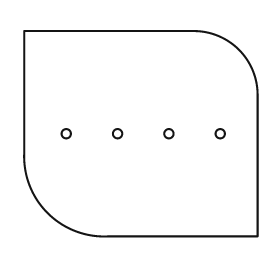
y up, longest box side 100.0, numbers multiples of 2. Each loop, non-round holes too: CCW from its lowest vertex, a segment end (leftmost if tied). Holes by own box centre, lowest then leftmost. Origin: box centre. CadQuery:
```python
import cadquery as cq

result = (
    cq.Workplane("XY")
    .moveTo(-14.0, -44.0)
    .lineTo(50.0, -44.0)
    .lineTo(50.0, 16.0)
    .threePointArc((42.0, 36.0), (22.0, 44.0))
    .lineTo(-50.0, 44.0)
    .lineTo(-50.0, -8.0)
    .threePointArc((-40.0, -34.0), (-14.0, -44.0))
    .close()
    .moveTo(-32.0, 0.0)
    .circle(2.0)
    .moveTo(-10.0, 0.0)
    .circle(2.0)
    .moveTo(12.0, 0.0)
    .circle(2.0)
    .moveTo(34.0, 0.0)
    .circle(2.0)
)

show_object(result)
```